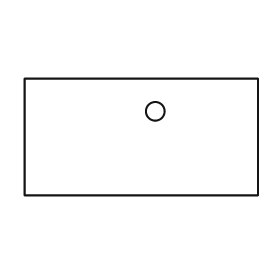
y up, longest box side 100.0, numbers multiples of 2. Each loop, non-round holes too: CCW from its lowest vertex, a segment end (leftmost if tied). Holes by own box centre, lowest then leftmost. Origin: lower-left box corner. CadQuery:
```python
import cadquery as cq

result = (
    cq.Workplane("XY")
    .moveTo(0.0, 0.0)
    .lineTo(100.0, 0.0)
    .lineTo(100.0, 50.0)
    .lineTo(0.0, 50.0)
    .close()
    .moveTo(56.0, 36.0)
    .circle(4.0)
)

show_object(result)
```